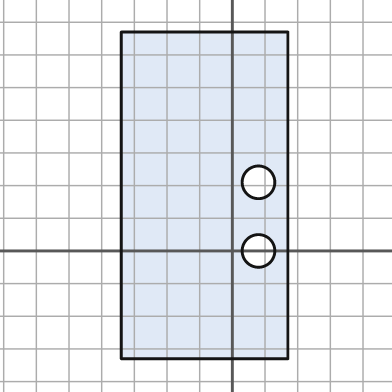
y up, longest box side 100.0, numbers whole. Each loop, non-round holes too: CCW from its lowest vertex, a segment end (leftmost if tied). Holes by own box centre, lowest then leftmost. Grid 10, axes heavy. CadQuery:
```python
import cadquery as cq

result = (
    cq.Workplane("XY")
    .moveTo(-34.0, -33.0)
    .lineTo(17.0, -33.0)
    .lineTo(17.0, 67.0)
    .lineTo(-34.0, 67.0)
    .close()
    .moveTo(8.0, 0.0)
    .circle(5.0)
    .moveTo(8.0, 21.0)
    .circle(5.0)
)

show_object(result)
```